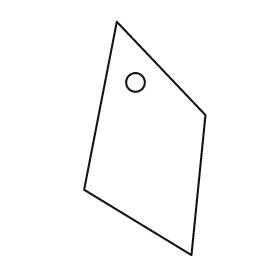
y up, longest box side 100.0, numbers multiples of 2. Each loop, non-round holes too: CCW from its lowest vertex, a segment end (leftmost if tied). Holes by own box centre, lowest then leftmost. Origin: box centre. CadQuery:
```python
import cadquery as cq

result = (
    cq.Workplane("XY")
    .moveTo(20.0, -50.0)
    .lineTo(26.0, 10.0)
    .lineTo(-12.0, 50.0)
    .lineTo(-26.0, -22.0)
    .close()
    .moveTo(-4.0, 24.0)
    .circle(4.0)
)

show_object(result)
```